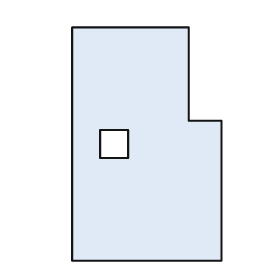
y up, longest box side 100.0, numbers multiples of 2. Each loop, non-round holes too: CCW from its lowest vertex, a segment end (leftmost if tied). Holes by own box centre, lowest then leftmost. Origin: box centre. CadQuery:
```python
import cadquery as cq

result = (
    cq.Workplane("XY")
    .moveTo(-32.0, -50.0)
    .lineTo(32.0, -50.0)
    .lineTo(32.0, 10.0)
    .lineTo(18.0, 10.0)
    .lineTo(18.0, 50.0)
    .lineTo(-32.0, 50.0)
    .close()
    .moveTo(-20.0, -6.0)
    .lineTo(-8.0, -6.0)
    .lineTo(-8.0, 6.0)
    .lineTo(-20.0, 6.0)
    .close()
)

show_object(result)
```